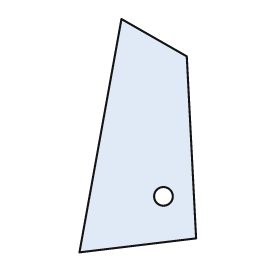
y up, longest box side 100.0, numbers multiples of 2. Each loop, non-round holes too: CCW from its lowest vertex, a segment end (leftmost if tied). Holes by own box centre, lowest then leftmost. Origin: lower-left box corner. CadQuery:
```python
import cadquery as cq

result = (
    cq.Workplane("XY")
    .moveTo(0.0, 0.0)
    .lineTo(50.0, 6.0)
    .lineTo(46.0, 84.0)
    .lineTo(18.0, 100.0)
    .close()
    .moveTo(36.0, 24.0)
    .circle(4.0)
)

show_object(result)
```